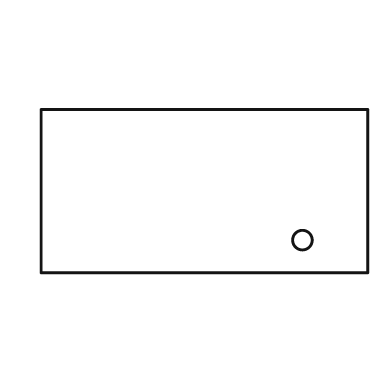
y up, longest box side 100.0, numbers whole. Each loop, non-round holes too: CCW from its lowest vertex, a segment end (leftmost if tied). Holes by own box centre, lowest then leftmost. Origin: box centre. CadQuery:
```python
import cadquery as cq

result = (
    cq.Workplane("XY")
    .moveTo(-50.0, -25.0)
    .lineTo(50.0, -25.0)
    .lineTo(50.0, 25.0)
    .lineTo(-50.0, 25.0)
    .close()
    .moveTo(30.0, -15.0)
    .circle(3.0)
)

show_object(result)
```